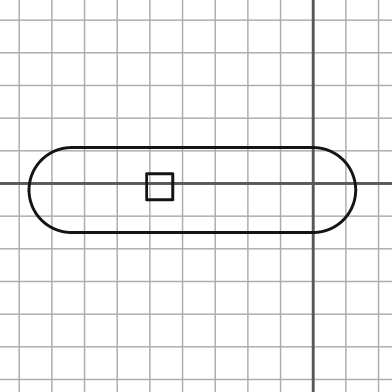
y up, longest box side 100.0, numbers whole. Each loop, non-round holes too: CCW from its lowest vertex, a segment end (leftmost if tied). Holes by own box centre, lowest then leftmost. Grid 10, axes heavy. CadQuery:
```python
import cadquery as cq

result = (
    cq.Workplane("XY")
    .moveTo(-74.0, -15.0)
    .lineTo(0.0, -15.0)
    .threePointArc((13.0, -2.0), (0.0, 11.0))
    .lineTo(-74.0, 11.0)
    .threePointArc((-87.0, -2.0), (-74.0, -15.0))
    .close()
    .moveTo(-51.0, -5.0)
    .lineTo(-43.0, -5.0)
    .lineTo(-43.0, 3.0)
    .lineTo(-51.0, 3.0)
    .close()
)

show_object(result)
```